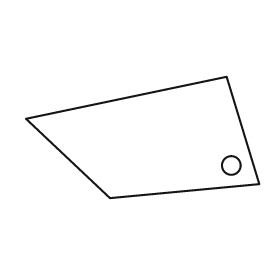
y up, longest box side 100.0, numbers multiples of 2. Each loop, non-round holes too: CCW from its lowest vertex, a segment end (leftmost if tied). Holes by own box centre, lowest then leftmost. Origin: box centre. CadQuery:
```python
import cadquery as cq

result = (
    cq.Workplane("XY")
    .moveTo(-14.0, -26.0)
    .lineTo(50.0, -20.0)
    .lineTo(36.0, 26.0)
    .lineTo(-50.0, 8.0)
    .close()
    .moveTo(38.0, -12.0)
    .circle(4.0)
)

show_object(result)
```